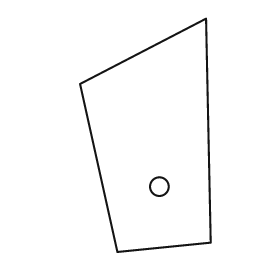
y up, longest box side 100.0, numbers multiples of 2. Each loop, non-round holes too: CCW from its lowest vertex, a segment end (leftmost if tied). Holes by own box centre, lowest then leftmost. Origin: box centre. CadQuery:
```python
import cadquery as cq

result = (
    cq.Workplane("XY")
    .moveTo(-12.0, -50.0)
    .lineTo(28.0, -46.0)
    .lineTo(26.0, 50.0)
    .lineTo(-28.0, 22.0)
    .close()
    .moveTo(6.0, -22.0)
    .circle(4.0)
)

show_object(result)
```